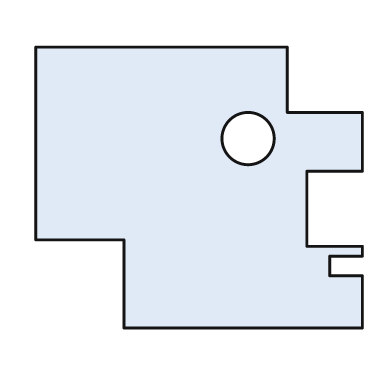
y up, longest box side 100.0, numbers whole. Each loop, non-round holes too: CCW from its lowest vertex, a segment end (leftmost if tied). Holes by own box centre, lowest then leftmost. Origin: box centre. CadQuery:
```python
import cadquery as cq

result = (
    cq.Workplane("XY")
    .moveTo(-23.0, -43.0)
    .lineTo(50.0, -43.0)
    .lineTo(50.0, -27.0)
    .lineTo(40.0, -27.0)
    .lineTo(40.0, -21.0)
    .lineTo(50.0, -21.0)
    .lineTo(50.0, -18.0)
    .lineTo(33.0, -18.0)
    .lineTo(33.0, 5.0)
    .lineTo(50.0, 5.0)
    .lineTo(50.0, 23.0)
    .lineTo(27.0, 23.0)
    .lineTo(27.0, 43.0)
    .lineTo(-50.0, 43.0)
    .lineTo(-50.0, -16.0)
    .lineTo(-23.0, -16.0)
    .close()
    .moveTo(15.0, 15.0)
    .circle(8.0)
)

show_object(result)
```